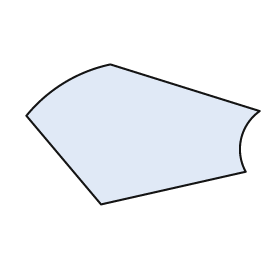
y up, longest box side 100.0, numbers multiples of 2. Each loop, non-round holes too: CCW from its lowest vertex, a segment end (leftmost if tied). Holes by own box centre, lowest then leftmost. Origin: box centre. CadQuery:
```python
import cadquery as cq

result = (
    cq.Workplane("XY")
    .moveTo(-18.0, -30.0)
    .lineTo(44.0, -16.0)
    .threePointArc((42.0, -2.0), (50.0, 10.0))
    .lineTo(-14.0, 30.0)
    .threePointArc((-34.0, 22.0), (-50.0, 8.0))
    .close()
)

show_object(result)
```